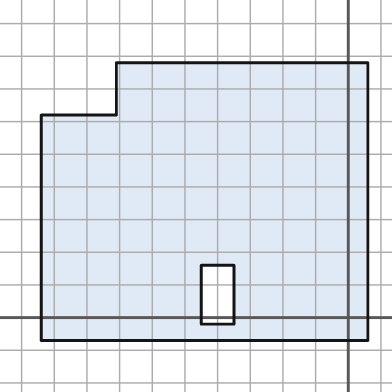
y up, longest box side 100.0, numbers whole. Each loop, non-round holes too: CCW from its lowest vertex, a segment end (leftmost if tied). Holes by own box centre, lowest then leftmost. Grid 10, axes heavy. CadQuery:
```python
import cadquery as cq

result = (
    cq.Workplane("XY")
    .moveTo(-94.0, -7.0)
    .lineTo(6.0, -7.0)
    .lineTo(6.0, 78.0)
    .lineTo(-71.0, 78.0)
    .lineTo(-71.0, 62.0)
    .lineTo(-94.0, 62.0)
    .close()
    .moveTo(-45.0, -2.0)
    .lineTo(-35.0, -2.0)
    .lineTo(-35.0, 16.0)
    .lineTo(-45.0, 16.0)
    .close()
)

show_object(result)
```